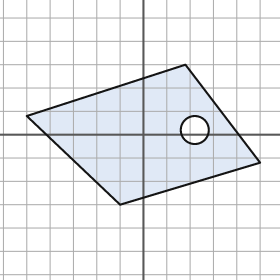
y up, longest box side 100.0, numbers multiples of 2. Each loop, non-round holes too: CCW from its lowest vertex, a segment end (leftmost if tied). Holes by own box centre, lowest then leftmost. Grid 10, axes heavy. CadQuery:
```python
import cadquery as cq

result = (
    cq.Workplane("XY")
    .moveTo(-10.0, -30.0)
    .lineTo(50.0, -12.0)
    .lineTo(18.0, 30.0)
    .lineTo(-50.0, 8.0)
    .close()
    .moveTo(22.0, 2.0)
    .circle(6.0)
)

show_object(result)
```